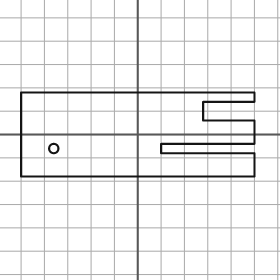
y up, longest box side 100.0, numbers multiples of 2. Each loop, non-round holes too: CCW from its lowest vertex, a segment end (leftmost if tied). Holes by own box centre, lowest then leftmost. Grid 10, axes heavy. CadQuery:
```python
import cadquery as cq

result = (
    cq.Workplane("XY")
    .moveTo(-50.0, -18.0)
    .lineTo(50.0, -18.0)
    .lineTo(50.0, -8.0)
    .lineTo(10.0, -8.0)
    .lineTo(10.0, -4.0)
    .lineTo(50.0, -4.0)
    .lineTo(50.0, 6.0)
    .lineTo(28.0, 6.0)
    .lineTo(28.0, 14.0)
    .lineTo(50.0, 14.0)
    .lineTo(50.0, 18.0)
    .lineTo(-50.0, 18.0)
    .close()
    .moveTo(-36.0, -6.0)
    .circle(2.0)
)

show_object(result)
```